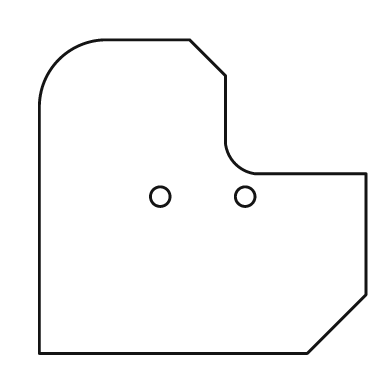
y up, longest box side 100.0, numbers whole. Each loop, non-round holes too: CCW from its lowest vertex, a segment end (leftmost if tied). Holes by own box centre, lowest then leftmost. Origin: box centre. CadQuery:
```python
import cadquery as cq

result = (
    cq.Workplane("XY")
    .moveTo(-50.0, -48.0)
    .lineTo(32.0, -48.0)
    .lineTo(50.0, -30.0)
    .lineTo(50.0, 7.0)
    .lineTo(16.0, 7.0)
    .threePointArc((10.0, 10.0), (7.0, 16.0))
    .lineTo(7.0, 37.0)
    .lineTo(-4.0, 48.0)
    .lineTo(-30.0, 48.0)
    .threePointArc((-44.0, 42.0), (-50.0, 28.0))
    .close()
    .moveTo(-13.0, 0.0)
    .circle(3.0)
    .moveTo(13.0, 0.0)
    .circle(3.0)
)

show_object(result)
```